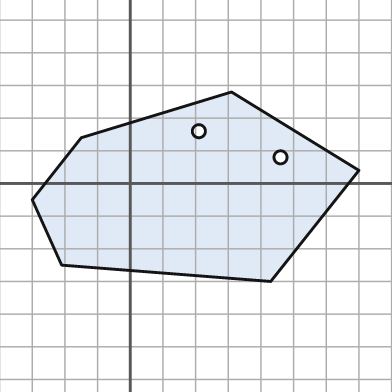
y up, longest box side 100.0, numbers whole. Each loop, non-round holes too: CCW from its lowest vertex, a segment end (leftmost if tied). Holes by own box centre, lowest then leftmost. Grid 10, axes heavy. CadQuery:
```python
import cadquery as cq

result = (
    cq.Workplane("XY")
    .moveTo(43.0, -30.0)
    .lineTo(70.0, 4.0)
    .lineTo(31.0, 28.0)
    .lineTo(-15.0, 14.0)
    .lineTo(-30.0, -5.0)
    .lineTo(-21.0, -25.0)
    .close()
    .moveTo(46.0, 8.0)
    .circle(2.0)
    .moveTo(21.0, 16.0)
    .circle(2.0)
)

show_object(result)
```